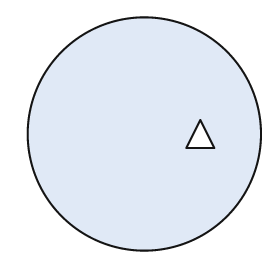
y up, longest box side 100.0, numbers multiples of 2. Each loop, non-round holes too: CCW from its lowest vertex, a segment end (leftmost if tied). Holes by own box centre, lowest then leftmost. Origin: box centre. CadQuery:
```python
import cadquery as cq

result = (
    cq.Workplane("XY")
    .moveTo(0.0, 0.0)
    .circle(50.0)
    .moveTo(18.0, -6.0)
    .lineTo(30.0, -6.0)
    .lineTo(24.0, 6.0)
    .close()
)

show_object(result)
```